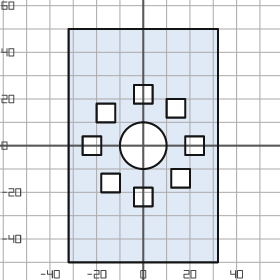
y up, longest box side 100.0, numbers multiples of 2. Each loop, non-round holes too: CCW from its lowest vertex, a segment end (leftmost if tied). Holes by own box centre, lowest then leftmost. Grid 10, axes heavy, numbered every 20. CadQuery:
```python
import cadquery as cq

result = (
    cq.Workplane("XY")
    .moveTo(-32.0, -50.0)
    .lineTo(32.0, -50.0)
    .lineTo(32.0, 50.0)
    .lineTo(-32.0, 50.0)
    .close()
    .moveTo(-4.0, -26.0)
    .lineTo(4.0, -26.0)
    .lineTo(4.0, -18.0)
    .lineTo(-4.0, -18.0)
    .close()
    .moveTo(-18.0, -20.0)
    .lineTo(-10.0, -20.0)
    .lineTo(-10.0, -12.0)
    .lineTo(-18.0, -12.0)
    .close()
    .moveTo(12.0, -18.0)
    .lineTo(20.0, -18.0)
    .lineTo(20.0, -10.0)
    .lineTo(12.0, -10.0)
    .close()
    .moveTo(-26.0, -4.0)
    .lineTo(-18.0, -4.0)
    .lineTo(-18.0, 4.0)
    .lineTo(-26.0, 4.0)
    .close()
    .moveTo(0.0, 0.0)
    .circle(10.0)
    .moveTo(18.0, -4.0)
    .lineTo(26.0, -4.0)
    .lineTo(26.0, 4.0)
    .lineTo(18.0, 4.0)
    .close()
    .moveTo(-20.0, 10.0)
    .lineTo(-12.0, 10.0)
    .lineTo(-12.0, 18.0)
    .lineTo(-20.0, 18.0)
    .close()
    .moveTo(10.0, 12.0)
    .lineTo(18.0, 12.0)
    .lineTo(18.0, 20.0)
    .lineTo(10.0, 20.0)
    .close()
    .moveTo(-4.0, 18.0)
    .lineTo(4.0, 18.0)
    .lineTo(4.0, 26.0)
    .lineTo(-4.0, 26.0)
    .close()
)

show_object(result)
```